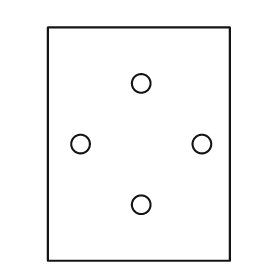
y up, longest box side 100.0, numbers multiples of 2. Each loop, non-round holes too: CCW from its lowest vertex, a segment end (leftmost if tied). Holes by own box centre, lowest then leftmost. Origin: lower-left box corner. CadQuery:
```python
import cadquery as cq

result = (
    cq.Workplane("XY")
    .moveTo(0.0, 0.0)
    .lineTo(78.0, 0.0)
    .lineTo(78.0, 100.0)
    .lineTo(0.0, 100.0)
    .close()
    .moveTo(40.0, 24.0)
    .circle(4.0)
    .moveTo(14.0, 50.0)
    .circle(4.0)
    .moveTo(66.0, 50.0)
    .circle(4.0)
    .moveTo(40.0, 76.0)
    .circle(4.0)
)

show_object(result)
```